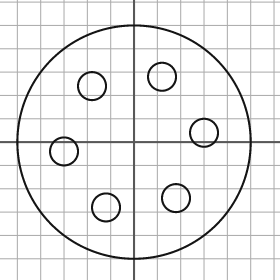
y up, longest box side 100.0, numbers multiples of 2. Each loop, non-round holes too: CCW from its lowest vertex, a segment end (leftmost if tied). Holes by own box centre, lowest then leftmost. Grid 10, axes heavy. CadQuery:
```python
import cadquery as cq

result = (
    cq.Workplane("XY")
    .moveTo(0.0, 0.0)
    .circle(50.0)
    .moveTo(-12.0, -28.0)
    .circle(6.0)
    .moveTo(18.0, -24.0)
    .circle(6.0)
    .moveTo(-30.0, -4.0)
    .circle(6.0)
    .moveTo(30.0, 4.0)
    .circle(6.0)
    .moveTo(-18.0, 24.0)
    .circle(6.0)
    .moveTo(12.0, 28.0)
    .circle(6.0)
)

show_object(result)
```